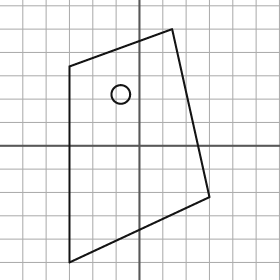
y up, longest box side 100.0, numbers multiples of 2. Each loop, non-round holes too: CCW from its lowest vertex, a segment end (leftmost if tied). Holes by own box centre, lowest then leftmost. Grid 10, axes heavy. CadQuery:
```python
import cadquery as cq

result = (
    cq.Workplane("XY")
    .moveTo(-30.0, -50.0)
    .lineTo(30.0, -22.0)
    .lineTo(14.0, 50.0)
    .lineTo(-30.0, 34.0)
    .close()
    .moveTo(-8.0, 22.0)
    .circle(4.0)
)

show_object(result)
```